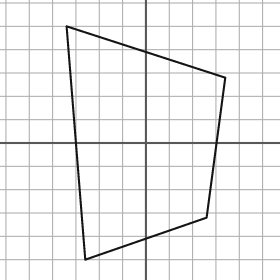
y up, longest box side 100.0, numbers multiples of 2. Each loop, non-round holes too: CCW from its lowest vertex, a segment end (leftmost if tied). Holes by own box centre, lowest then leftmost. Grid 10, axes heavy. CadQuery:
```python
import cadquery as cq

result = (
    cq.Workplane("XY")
    .moveTo(-26.0, -50.0)
    .lineTo(26.0, -32.0)
    .lineTo(34.0, 28.0)
    .lineTo(-34.0, 50.0)
    .close()
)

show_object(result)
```